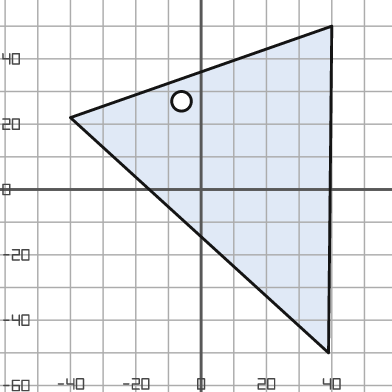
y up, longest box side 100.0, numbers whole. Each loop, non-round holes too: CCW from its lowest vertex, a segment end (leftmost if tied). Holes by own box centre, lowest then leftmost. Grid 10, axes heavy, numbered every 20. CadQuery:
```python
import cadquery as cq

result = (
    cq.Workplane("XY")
    .moveTo(39.0, -50.0)
    .lineTo(40.0, 50.0)
    .lineTo(-40.0, 22.0)
    .close()
    .moveTo(-6.0, 27.0)
    .circle(3.0)
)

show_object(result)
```